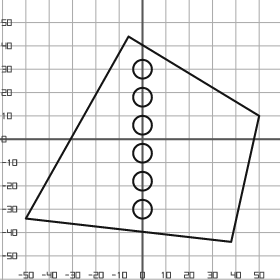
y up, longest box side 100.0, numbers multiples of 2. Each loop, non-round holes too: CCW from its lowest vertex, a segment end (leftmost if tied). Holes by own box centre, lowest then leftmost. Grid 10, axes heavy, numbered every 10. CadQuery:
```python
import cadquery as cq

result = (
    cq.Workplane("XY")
    .moveTo(38.0, -44.0)
    .lineTo(50.0, 10.0)
    .lineTo(-6.0, 44.0)
    .lineTo(-50.0, -34.0)
    .close()
    .moveTo(0.0, -30.0)
    .circle(4.0)
    .moveTo(0.0, -18.0)
    .circle(4.0)
    .moveTo(0.0, -6.0)
    .circle(4.0)
    .moveTo(0.0, 6.0)
    .circle(4.0)
    .moveTo(0.0, 18.0)
    .circle(4.0)
    .moveTo(0.0, 30.0)
    .circle(4.0)
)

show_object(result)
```